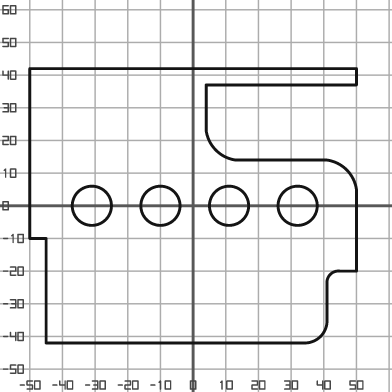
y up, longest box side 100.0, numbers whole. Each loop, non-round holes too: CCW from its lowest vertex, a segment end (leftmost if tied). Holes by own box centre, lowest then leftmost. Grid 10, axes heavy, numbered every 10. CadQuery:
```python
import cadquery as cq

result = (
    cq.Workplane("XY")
    .moveTo(-45.0, -42.0)
    .lineTo(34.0, -42.0)
    .threePointArc((39.0, -40.0), (41.0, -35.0))
    .lineTo(41.0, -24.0)
    .threePointArc((42.0, -21.0), (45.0, -20.0))
    .lineTo(50.0, -20.0)
    .lineTo(50.0, 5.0)
    .threePointArc((47.0, 11.0), (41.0, 14.0))
    .lineTo(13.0, 14.0)
    .threePointArc((7.0, 17.0), (4.0, 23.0))
    .lineTo(4.0, 37.0)
    .lineTo(50.0, 37.0)
    .lineTo(50.0, 42.0)
    .lineTo(-50.0, 42.0)
    .lineTo(-50.0, -10.0)
    .lineTo(-45.0, -10.0)
    .close()
    .moveTo(-31.0, 0.0)
    .circle(6.0)
    .moveTo(-10.0, 0.0)
    .circle(6.0)
    .moveTo(11.0, 0.0)
    .circle(6.0)
    .moveTo(32.0, 0.0)
    .circle(6.0)
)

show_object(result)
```